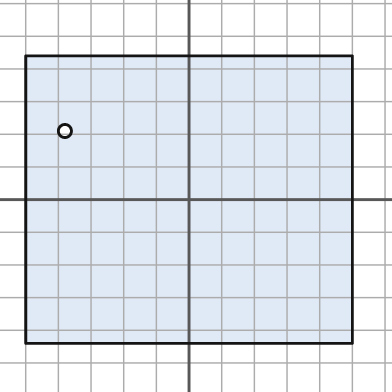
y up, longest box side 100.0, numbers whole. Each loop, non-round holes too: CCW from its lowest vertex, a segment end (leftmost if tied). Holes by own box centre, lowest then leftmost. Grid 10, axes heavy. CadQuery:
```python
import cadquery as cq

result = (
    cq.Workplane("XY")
    .moveTo(-50.0, -44.0)
    .lineTo(50.0, -44.0)
    .lineTo(50.0, 44.0)
    .lineTo(-50.0, 44.0)
    .close()
    .moveTo(-38.0, 21.0)
    .circle(2.0)
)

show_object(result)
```